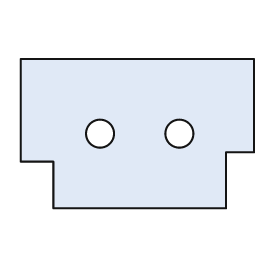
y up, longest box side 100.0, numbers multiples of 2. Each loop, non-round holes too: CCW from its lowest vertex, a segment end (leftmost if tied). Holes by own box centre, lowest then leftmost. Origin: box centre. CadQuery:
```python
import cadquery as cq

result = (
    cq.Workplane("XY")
    .moveTo(-36.0, -32.0)
    .lineTo(38.0, -32.0)
    .lineTo(38.0, -8.0)
    .lineTo(50.0, -8.0)
    .lineTo(50.0, 32.0)
    .lineTo(-50.0, 32.0)
    .lineTo(-50.0, -12.0)
    .lineTo(-36.0, -12.0)
    .close()
    .moveTo(-16.0, 0.0)
    .circle(6.0)
    .moveTo(18.0, 0.0)
    .circle(6.0)
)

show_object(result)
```